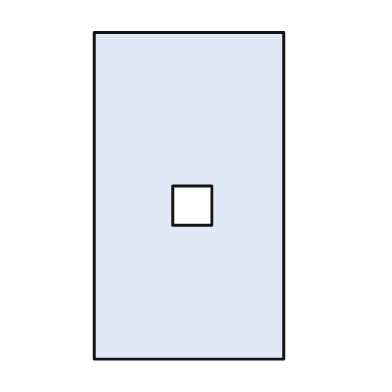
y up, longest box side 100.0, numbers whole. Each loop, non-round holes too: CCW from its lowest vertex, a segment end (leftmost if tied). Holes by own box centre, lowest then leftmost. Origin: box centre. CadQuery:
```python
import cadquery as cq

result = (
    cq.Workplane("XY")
    .moveTo(-29.0, -50.0)
    .lineTo(29.0, -50.0)
    .lineTo(29.0, 50.0)
    .lineTo(-29.0, 50.0)
    .close()
    .moveTo(-5.0, -9.0)
    .lineTo(7.0, -9.0)
    .lineTo(7.0, 3.0)
    .lineTo(-5.0, 3.0)
    .close()
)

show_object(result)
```